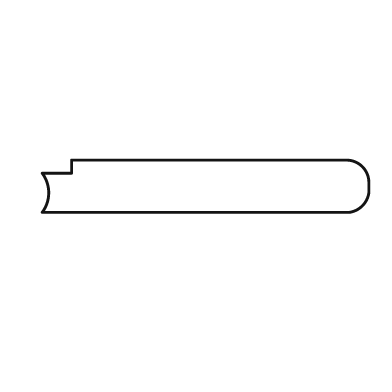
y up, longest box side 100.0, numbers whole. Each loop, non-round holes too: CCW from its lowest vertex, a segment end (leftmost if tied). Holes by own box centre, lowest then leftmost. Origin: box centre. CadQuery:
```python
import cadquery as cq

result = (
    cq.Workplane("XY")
    .moveTo(-50.0, -8.0)
    .lineTo(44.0, -8.0)
    .threePointArc((48.0, -6.0), (50.0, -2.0))
    .lineTo(50.0, 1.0)
    .threePointArc((48.0, 6.0), (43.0, 8.0))
    .lineTo(-41.0, 8.0)
    .lineTo(-41.0, 4.0)
    .lineTo(-50.0, 4.0)
    .threePointArc((-48.0, -2.0), (-50.0, -8.0))
    .close()
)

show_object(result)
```